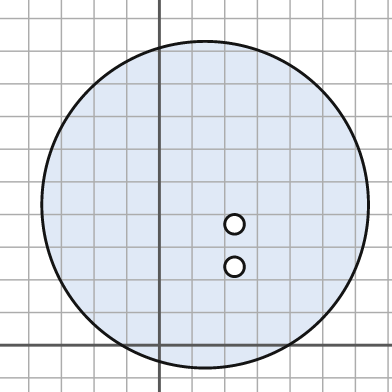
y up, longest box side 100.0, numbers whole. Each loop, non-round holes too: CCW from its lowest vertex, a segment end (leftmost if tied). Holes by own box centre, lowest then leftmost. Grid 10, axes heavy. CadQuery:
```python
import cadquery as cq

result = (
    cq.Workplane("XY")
    .moveTo(14.0, 43.0)
    .circle(50.0)
    .moveTo(23.0, 24.0)
    .circle(3.0)
    .moveTo(23.0, 37.0)
    .circle(3.0)
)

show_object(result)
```